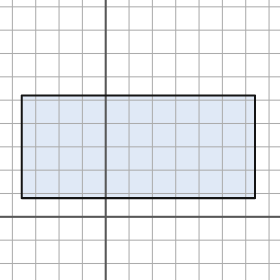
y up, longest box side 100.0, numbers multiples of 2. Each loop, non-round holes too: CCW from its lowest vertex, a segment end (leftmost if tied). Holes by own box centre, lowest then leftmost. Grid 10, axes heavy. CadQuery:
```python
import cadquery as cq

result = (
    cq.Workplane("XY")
    .moveTo(-36.0, 8.0)
    .lineTo(64.0, 8.0)
    .lineTo(64.0, 52.0)
    .lineTo(-36.0, 52.0)
    .close()
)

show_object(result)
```